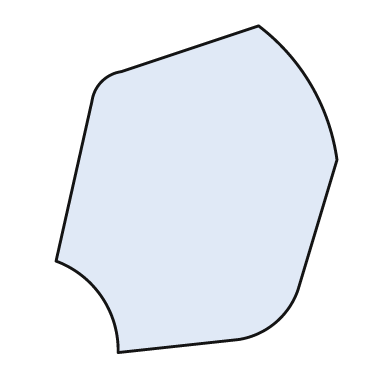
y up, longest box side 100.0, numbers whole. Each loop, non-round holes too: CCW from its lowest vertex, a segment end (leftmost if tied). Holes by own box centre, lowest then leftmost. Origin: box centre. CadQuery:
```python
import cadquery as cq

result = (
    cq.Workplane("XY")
    .moveTo(-24.0, -50.0)
    .lineTo(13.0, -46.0)
    .threePointArc((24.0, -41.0), (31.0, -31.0))
    .lineTo(43.0, 9.0)
    .threePointArc((35.0, 32.0), (19.0, 50.0))
    .lineTo(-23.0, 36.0)
    .threePointArc((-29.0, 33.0), (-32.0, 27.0))
    .lineTo(-43.0, -22.0)
    .threePointArc((-29.0, -33.0), (-24.0, -50.0))
    .close()
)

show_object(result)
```